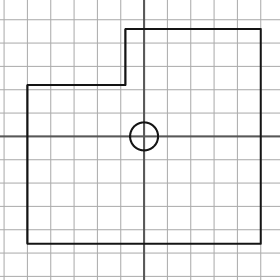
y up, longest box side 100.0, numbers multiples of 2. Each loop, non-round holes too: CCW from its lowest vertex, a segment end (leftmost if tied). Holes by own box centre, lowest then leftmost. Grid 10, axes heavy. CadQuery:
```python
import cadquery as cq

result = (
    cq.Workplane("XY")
    .moveTo(-50.0, -46.0)
    .lineTo(50.0, -46.0)
    .lineTo(50.0, 46.0)
    .lineTo(-8.0, 46.0)
    .lineTo(-8.0, 22.0)
    .lineTo(-50.0, 22.0)
    .close()
    .moveTo(0.0, 0.0)
    .circle(6.0)
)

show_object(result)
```